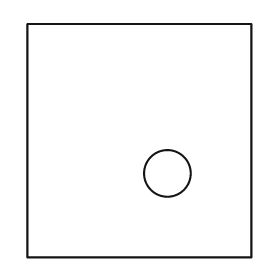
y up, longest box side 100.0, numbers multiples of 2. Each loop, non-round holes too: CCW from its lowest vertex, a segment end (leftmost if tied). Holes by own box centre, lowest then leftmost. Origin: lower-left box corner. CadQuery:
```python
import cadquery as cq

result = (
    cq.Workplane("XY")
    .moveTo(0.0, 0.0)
    .lineTo(96.0, 0.0)
    .lineTo(96.0, 100.0)
    .lineTo(0.0, 100.0)
    .close()
    .moveTo(60.0, 36.0)
    .circle(10.0)
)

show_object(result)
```